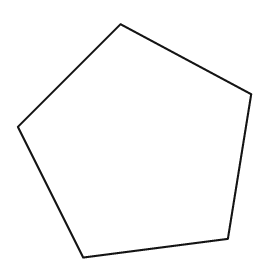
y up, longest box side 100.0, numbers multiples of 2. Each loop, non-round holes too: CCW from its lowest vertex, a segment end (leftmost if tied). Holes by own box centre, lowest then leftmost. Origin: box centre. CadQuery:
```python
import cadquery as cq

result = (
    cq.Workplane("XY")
    .moveTo(-22.0, -50.0)
    .lineTo(40.0, -42.0)
    .lineTo(50.0, 20.0)
    .lineTo(-6.0, 50.0)
    .lineTo(-50.0, 6.0)
    .close()
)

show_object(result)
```